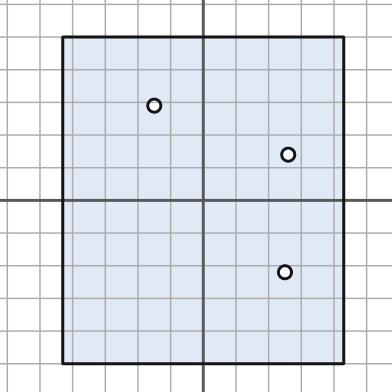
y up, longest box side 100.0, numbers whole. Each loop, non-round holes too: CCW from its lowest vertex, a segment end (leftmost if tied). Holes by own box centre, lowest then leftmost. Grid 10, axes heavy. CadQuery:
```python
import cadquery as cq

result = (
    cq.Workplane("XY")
    .moveTo(-43.0, -50.0)
    .lineTo(43.0, -50.0)
    .lineTo(43.0, 50.0)
    .lineTo(-43.0, 50.0)
    .close()
    .moveTo(25.0, -22.0)
    .circle(2.0)
    .moveTo(26.0, 14.0)
    .circle(2.0)
    .moveTo(-15.0, 29.0)
    .circle(2.0)
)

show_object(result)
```